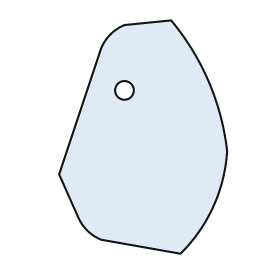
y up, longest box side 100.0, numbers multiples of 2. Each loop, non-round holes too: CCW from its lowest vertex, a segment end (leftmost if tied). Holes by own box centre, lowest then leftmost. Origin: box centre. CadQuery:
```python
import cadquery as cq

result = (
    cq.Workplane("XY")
    .moveTo(16.0, -50.0)
    .threePointArc((30.0, -30.0), (36.0, -6.0))
    .threePointArc((28.0, 24.0), (12.0, 50.0))
    .lineTo(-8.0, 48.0)
    .threePointArc((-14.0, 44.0), (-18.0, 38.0))
    .lineTo(-36.0, -16.0)
    .lineTo(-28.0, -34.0)
    .threePointArc((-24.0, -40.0), (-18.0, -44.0))
    .close()
    .moveTo(-8.0, 20.0)
    .circle(4.0)
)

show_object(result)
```